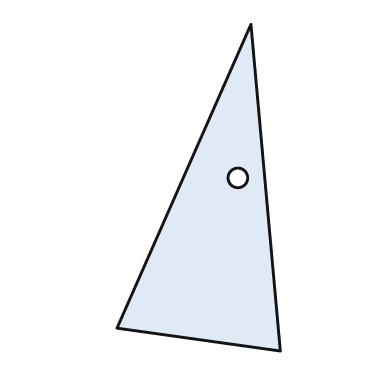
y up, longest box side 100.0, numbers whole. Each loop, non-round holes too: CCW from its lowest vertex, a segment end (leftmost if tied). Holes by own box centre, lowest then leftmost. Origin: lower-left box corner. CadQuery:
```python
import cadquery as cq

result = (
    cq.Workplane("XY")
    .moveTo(50.0, 0.0)
    .lineTo(41.0, 100.0)
    .lineTo(0.0, 7.0)
    .close()
    .moveTo(37.0, 53.0)
    .circle(3.0)
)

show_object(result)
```